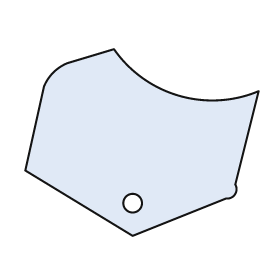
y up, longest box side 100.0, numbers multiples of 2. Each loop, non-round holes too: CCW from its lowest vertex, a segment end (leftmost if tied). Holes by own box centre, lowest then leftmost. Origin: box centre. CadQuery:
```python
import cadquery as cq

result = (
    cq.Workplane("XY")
    .moveTo(-4.0, -40.0)
    .lineTo(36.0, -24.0)
    .threePointArc((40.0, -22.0), (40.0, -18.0))
    .lineTo(50.0, 22.0)
    .threePointArc((16.0, 20.0), (-12.0, 40.0))
    .lineTo(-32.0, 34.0)
    .threePointArc((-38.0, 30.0), (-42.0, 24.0))
    .lineTo(-50.0, -12.0)
    .close()
    .moveTo(-4.0, -26.0)
    .circle(4.0)
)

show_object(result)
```